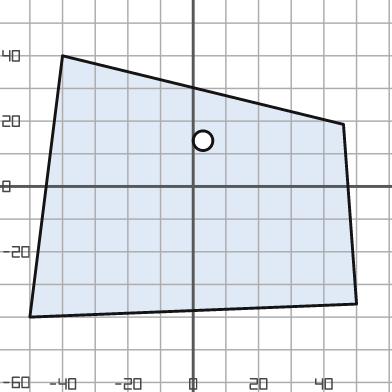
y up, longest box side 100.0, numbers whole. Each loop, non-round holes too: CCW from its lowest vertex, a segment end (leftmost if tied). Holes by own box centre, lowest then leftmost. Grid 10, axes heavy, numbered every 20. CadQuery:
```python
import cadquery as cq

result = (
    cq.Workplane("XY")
    .moveTo(-50.0, -40.0)
    .lineTo(50.0, -36.0)
    .lineTo(46.0, 19.0)
    .lineTo(-40.0, 40.0)
    .close()
    .moveTo(3.0, 14.0)
    .circle(3.0)
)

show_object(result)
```